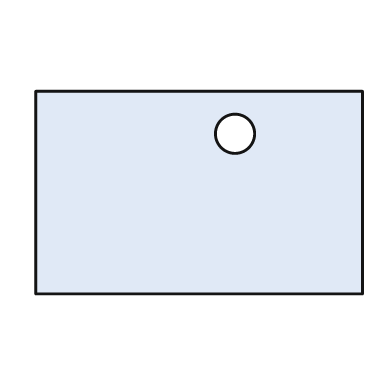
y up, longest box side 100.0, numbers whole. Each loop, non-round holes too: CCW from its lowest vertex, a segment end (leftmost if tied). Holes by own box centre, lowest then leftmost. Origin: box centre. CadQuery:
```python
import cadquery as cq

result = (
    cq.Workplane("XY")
    .moveTo(-50.0, -31.0)
    .lineTo(50.0, -31.0)
    .lineTo(50.0, 31.0)
    .lineTo(-50.0, 31.0)
    .close()
    .moveTo(11.0, 18.0)
    .circle(6.0)
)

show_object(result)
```